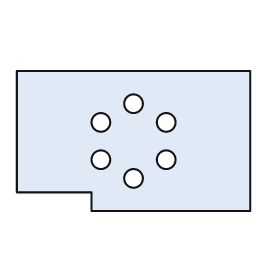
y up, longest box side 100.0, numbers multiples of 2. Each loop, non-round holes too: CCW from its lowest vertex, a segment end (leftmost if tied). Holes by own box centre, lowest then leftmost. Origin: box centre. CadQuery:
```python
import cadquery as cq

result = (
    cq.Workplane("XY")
    .moveTo(-18.0, -30.0)
    .lineTo(50.0, -30.0)
    .lineTo(50.0, 30.0)
    .lineTo(-50.0, 30.0)
    .lineTo(-50.0, -22.0)
    .lineTo(-18.0, -22.0)
    .close()
    .moveTo(0.0, -16.0)
    .circle(4.0)
    .moveTo(-14.0, -8.0)
    .circle(4.0)
    .moveTo(14.0, -8.0)
    .circle(4.0)
    .moveTo(-14.0, 8.0)
    .circle(4.0)
    .moveTo(14.0, 8.0)
    .circle(4.0)
    .moveTo(0.0, 16.0)
    .circle(4.0)
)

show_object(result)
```